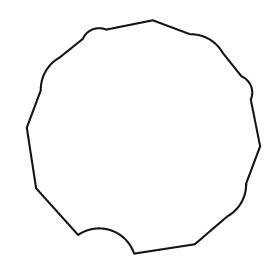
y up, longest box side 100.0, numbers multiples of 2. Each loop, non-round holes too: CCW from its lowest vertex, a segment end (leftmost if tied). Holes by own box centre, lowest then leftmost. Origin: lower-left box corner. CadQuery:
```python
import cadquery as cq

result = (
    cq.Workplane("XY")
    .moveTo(46.0, 0.0)
    .lineTo(72.0, 4.0)
    .lineTo(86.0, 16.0)
    .threePointArc((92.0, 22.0), (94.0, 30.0))
    .lineTo(100.0, 46.0)
    .lineTo(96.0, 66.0)
    .threePointArc((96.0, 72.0), (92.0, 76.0))
    .lineTo(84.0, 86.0)
    .threePointArc((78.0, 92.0), (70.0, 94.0))
    .lineTo(54.0, 100.0)
    .lineTo(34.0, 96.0)
    .threePointArc((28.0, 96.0), (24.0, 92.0))
    .lineTo(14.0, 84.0)
    .threePointArc((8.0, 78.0), (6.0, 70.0))
    .lineTo(0.0, 54.0)
    .lineTo(4.0, 28.0)
    .lineTo(22.0, 8.0)
    .threePointArc((36.0, 10.0), (46.0, 0.0))
    .close()
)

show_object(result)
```